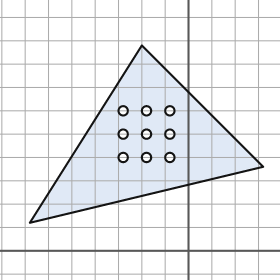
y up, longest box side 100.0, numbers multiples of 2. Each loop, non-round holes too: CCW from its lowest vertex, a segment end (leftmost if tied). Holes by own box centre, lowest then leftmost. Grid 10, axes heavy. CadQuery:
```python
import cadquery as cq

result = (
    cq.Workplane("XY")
    .moveTo(-68.0, 12.0)
    .lineTo(32.0, 36.0)
    .lineTo(-20.0, 88.0)
    .close()
    .moveTo(-28.0, 40.0)
    .circle(2.0)
    .moveTo(-18.0, 40.0)
    .circle(2.0)
    .moveTo(-8.0, 40.0)
    .circle(2.0)
    .moveTo(-28.0, 50.0)
    .circle(2.0)
    .moveTo(-18.0, 50.0)
    .circle(2.0)
    .moveTo(-8.0, 50.0)
    .circle(2.0)
    .moveTo(-28.0, 60.0)
    .circle(2.0)
    .moveTo(-18.0, 60.0)
    .circle(2.0)
    .moveTo(-8.0, 60.0)
    .circle(2.0)
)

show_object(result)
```